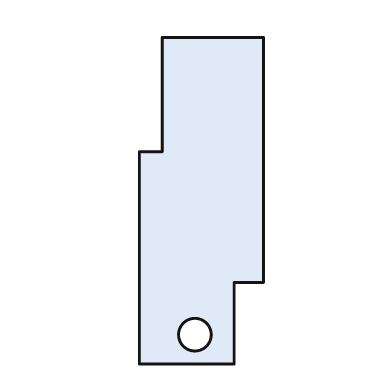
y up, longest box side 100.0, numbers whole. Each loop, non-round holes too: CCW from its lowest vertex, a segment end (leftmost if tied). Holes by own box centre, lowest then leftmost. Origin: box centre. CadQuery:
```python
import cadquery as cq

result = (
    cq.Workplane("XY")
    .moveTo(-19.0, -50.0)
    .lineTo(10.0, -50.0)
    .lineTo(10.0, -25.0)
    .lineTo(19.0, -25.0)
    .lineTo(19.0, 50.0)
    .lineTo(-12.0, 50.0)
    .lineTo(-12.0, 15.0)
    .lineTo(-19.0, 15.0)
    .close()
    .moveTo(-2.0, -41.0)
    .circle(5.0)
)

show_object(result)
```